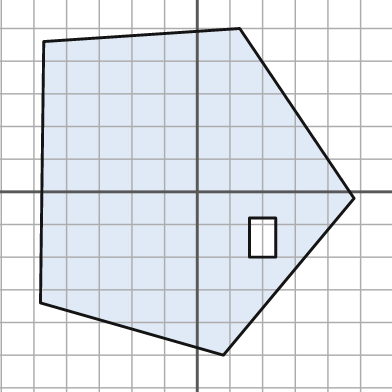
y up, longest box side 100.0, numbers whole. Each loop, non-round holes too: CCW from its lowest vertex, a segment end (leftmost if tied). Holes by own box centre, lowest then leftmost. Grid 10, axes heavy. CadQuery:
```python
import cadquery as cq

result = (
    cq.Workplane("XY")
    .moveTo(8.0, -50.0)
    .lineTo(48.0, -2.0)
    .lineTo(13.0, 50.0)
    .lineTo(-47.0, 46.0)
    .lineTo(-48.0, -34.0)
    .close()
    .moveTo(16.0, -20.0)
    .lineTo(24.0, -20.0)
    .lineTo(24.0, -8.0)
    .lineTo(16.0, -8.0)
    .close()
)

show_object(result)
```